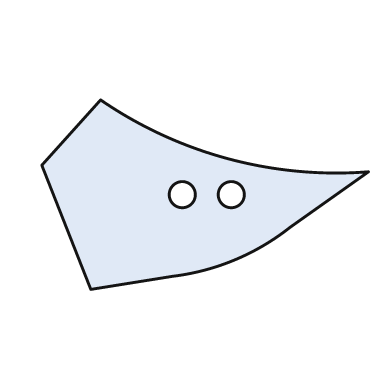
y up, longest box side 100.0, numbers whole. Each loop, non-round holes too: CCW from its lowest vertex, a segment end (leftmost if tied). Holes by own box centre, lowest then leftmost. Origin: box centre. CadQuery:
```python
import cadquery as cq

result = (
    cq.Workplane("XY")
    .moveTo(-35.0, -29.0)
    .lineTo(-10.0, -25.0)
    .threePointArc((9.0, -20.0), (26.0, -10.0))
    .lineTo(50.0, 7.0)
    .threePointArc((7.0, 11.0), (-32.0, 29.0))
    .lineTo(-50.0, 9.0)
    .close()
    .moveTo(-7.0, 0.0)
    .circle(4.0)
    .moveTo(8.0, 0.0)
    .circle(4.0)
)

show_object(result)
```